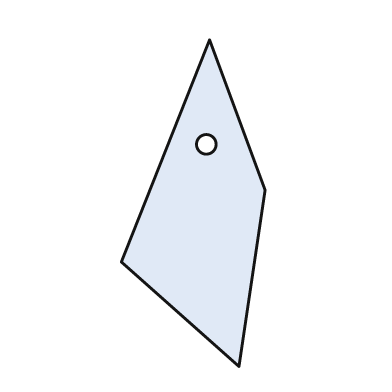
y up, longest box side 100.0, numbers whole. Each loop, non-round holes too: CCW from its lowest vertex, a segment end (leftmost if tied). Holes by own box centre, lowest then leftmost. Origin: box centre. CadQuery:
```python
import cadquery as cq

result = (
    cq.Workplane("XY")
    .moveTo(14.0, -50.0)
    .lineTo(22.0, 4.0)
    .lineTo(5.0, 50.0)
    .lineTo(-22.0, -18.0)
    .close()
    .moveTo(4.0, 18.0)
    .circle(3.0)
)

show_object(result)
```